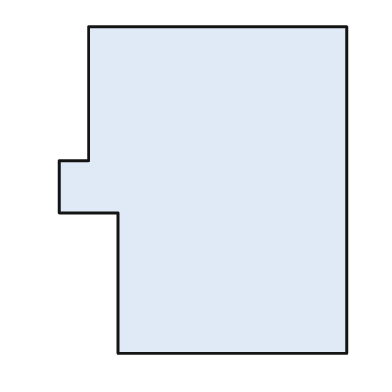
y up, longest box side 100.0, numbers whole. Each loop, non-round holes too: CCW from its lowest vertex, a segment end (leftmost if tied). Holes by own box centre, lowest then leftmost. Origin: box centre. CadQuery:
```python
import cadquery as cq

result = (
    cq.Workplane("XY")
    .moveTo(-26.0, -50.0)
    .lineTo(44.0, -50.0)
    .lineTo(44.0, 50.0)
    .lineTo(-35.0, 50.0)
    .lineTo(-35.0, 9.0)
    .lineTo(-44.0, 9.0)
    .lineTo(-44.0, -7.0)
    .lineTo(-26.0, -7.0)
    .close()
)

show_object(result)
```